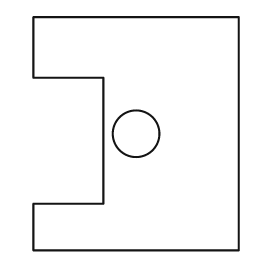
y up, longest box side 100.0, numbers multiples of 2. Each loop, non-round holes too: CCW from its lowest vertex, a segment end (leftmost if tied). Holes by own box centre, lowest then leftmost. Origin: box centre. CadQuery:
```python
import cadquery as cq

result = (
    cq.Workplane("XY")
    .moveTo(-44.0, -50.0)
    .lineTo(44.0, -50.0)
    .lineTo(44.0, 50.0)
    .lineTo(-44.0, 50.0)
    .lineTo(-44.0, 24.0)
    .lineTo(-14.0, 24.0)
    .lineTo(-14.0, -30.0)
    .lineTo(-44.0, -30.0)
    .close()
    .moveTo(0.0, 0.0)
    .circle(10.0)
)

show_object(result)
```